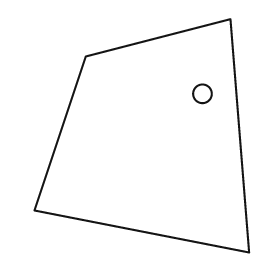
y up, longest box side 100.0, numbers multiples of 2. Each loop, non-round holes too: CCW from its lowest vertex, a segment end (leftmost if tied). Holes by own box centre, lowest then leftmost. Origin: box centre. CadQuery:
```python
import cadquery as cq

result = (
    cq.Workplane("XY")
    .moveTo(46.0, -50.0)
    .lineTo(38.0, 50.0)
    .lineTo(-24.0, 34.0)
    .lineTo(-46.0, -32.0)
    .close()
    .moveTo(26.0, 18.0)
    .circle(4.0)
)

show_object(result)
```